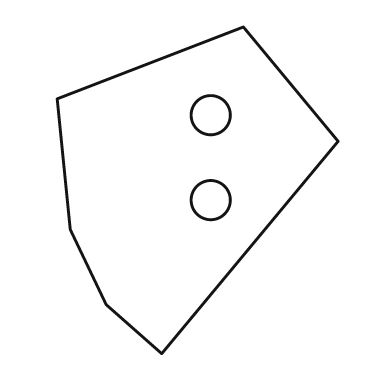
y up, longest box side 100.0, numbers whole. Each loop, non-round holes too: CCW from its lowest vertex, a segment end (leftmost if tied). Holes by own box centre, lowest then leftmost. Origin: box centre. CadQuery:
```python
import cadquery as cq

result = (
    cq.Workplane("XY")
    .moveTo(-11.0, -50.0)
    .lineTo(43.0, 15.0)
    .lineTo(14.0, 50.0)
    .lineTo(-43.0, 28.0)
    .lineTo(-39.0, -12.0)
    .lineTo(-28.0, -35.0)
    .close()
    .moveTo(4.0, -3.0)
    .circle(6.0)
    .moveTo(4.0, 23.0)
    .circle(6.0)
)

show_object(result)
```